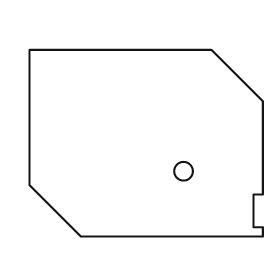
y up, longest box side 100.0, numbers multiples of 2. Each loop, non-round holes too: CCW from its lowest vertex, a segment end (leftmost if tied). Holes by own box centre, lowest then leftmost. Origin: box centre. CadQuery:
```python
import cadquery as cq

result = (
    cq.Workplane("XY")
    .moveTo(-28.0, -40.0)
    .lineTo(50.0, -40.0)
    .lineTo(50.0, -36.0)
    .lineTo(46.0, -36.0)
    .lineTo(46.0, -22.0)
    .lineTo(50.0, -22.0)
    .lineTo(50.0, 18.0)
    .lineTo(28.0, 40.0)
    .lineTo(-50.0, 40.0)
    .lineTo(-50.0, -18.0)
    .close()
    .moveTo(16.0, -12.0)
    .circle(4.0)
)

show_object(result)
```